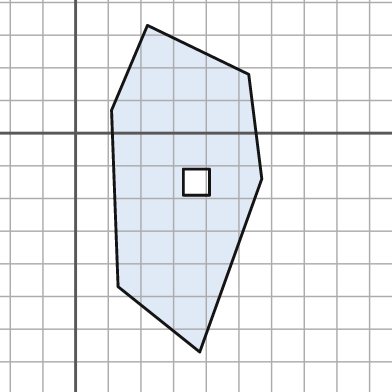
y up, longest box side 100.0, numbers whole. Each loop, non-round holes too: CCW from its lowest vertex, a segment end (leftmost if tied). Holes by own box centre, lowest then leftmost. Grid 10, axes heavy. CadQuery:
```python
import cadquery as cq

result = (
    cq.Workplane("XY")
    .moveTo(38.0, -67.0)
    .lineTo(57.0, -14.0)
    .lineTo(53.0, 18.0)
    .lineTo(22.0, 33.0)
    .lineTo(11.0, 7.0)
    .lineTo(13.0, -47.0)
    .close()
    .moveTo(33.0, -19.0)
    .lineTo(41.0, -19.0)
    .lineTo(41.0, -11.0)
    .lineTo(33.0, -11.0)
    .close()
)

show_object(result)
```